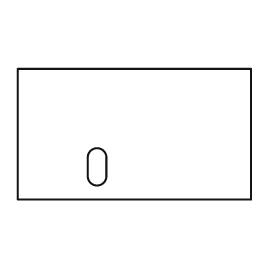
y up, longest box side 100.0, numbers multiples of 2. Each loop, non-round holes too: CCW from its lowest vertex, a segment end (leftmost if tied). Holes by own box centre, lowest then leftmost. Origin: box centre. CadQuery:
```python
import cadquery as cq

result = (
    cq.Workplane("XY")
    .moveTo(-50.0, -28.0)
    .lineTo(50.0, -28.0)
    .lineTo(50.0, 28.0)
    .lineTo(-50.0, 28.0)
    .close()
    .moveTo(-20.0, -18.0)
    .threePointArc((-16.0, -22.0), (-12.0, -18.0))
    .lineTo(-12.0, -10.0)
    .threePointArc((-16.0, -6.0), (-20.0, -10.0))
    .close()
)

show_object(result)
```